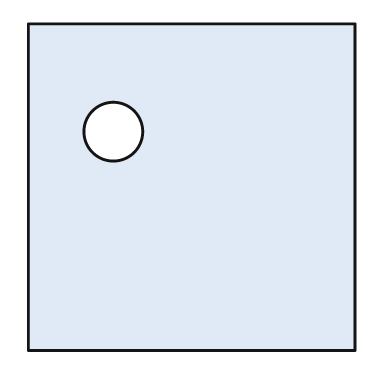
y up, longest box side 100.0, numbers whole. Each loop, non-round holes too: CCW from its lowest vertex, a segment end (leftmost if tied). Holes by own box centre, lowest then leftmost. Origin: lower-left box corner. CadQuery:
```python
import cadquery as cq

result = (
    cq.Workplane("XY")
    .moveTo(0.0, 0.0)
    .lineTo(100.0, 0.0)
    .lineTo(100.0, 100.0)
    .lineTo(0.0, 100.0)
    .close()
    .moveTo(26.0, 67.0)
    .circle(9.0)
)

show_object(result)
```